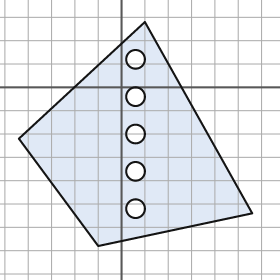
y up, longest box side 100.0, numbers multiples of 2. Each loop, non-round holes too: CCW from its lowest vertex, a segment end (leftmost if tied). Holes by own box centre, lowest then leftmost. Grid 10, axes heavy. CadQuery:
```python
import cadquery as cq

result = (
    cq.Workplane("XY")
    .moveTo(-10.0, -68.0)
    .lineTo(56.0, -54.0)
    .lineTo(10.0, 28.0)
    .lineTo(-44.0, -22.0)
    .close()
    .moveTo(6.0, -52.0)
    .circle(4.0)
    .moveTo(6.0, -36.0)
    .circle(4.0)
    .moveTo(6.0, -20.0)
    .circle(4.0)
    .moveTo(6.0, -4.0)
    .circle(4.0)
    .moveTo(6.0, 12.0)
    .circle(4.0)
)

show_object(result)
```